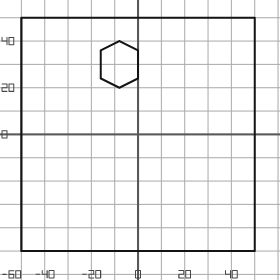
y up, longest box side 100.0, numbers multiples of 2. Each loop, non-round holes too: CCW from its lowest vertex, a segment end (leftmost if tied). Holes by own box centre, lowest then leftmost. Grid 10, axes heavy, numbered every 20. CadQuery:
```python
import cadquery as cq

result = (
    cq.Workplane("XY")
    .moveTo(-50.0, -50.0)
    .lineTo(50.0, -50.0)
    .lineTo(50.0, 50.0)
    .lineTo(-50.0, 50.0)
    .close()
    .moveTo(-8.0, 20.0)
    .lineTo(0.0, 24.0)
    .lineTo(0.0, 36.0)
    .lineTo(-8.0, 40.0)
    .lineTo(-16.0, 36.0)
    .lineTo(-16.0, 24.0)
    .close()
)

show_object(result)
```